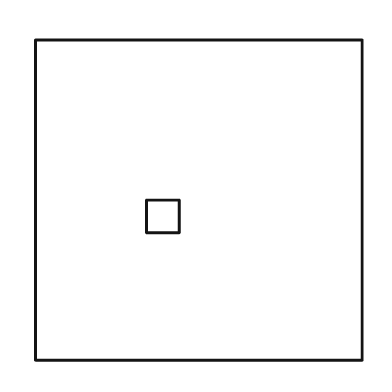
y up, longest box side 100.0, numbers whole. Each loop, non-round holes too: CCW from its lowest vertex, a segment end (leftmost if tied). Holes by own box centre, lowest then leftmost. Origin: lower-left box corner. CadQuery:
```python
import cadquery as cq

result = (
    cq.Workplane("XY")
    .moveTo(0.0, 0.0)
    .lineTo(100.0, 0.0)
    .lineTo(100.0, 98.0)
    .lineTo(0.0, 98.0)
    .close()
    .moveTo(34.0, 39.0)
    .lineTo(44.0, 39.0)
    .lineTo(44.0, 49.0)
    .lineTo(34.0, 49.0)
    .close()
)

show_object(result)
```